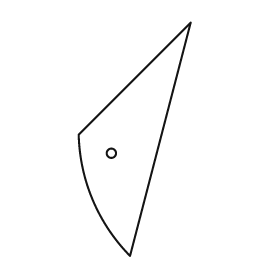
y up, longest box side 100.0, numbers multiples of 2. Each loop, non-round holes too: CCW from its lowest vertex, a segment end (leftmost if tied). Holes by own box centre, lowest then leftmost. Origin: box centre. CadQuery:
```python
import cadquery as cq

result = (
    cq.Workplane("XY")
    .moveTo(-2.0, -50.0)
    .lineTo(24.0, 50.0)
    .lineTo(-24.0, 2.0)
    .threePointArc((-18.0, -26.0), (-2.0, -50.0))
    .close()
    .moveTo(-10.0, -6.0)
    .circle(2.0)
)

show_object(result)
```